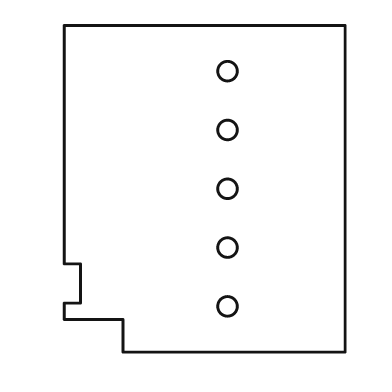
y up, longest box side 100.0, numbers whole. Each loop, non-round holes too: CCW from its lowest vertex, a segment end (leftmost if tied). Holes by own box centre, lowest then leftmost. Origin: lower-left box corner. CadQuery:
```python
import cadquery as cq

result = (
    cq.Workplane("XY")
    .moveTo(18.0, 0.0)
    .lineTo(86.0, 0.0)
    .lineTo(86.0, 100.0)
    .lineTo(0.0, 100.0)
    .lineTo(0.0, 27.0)
    .lineTo(5.0, 27.0)
    .lineTo(5.0, 15.0)
    .lineTo(0.0, 15.0)
    .lineTo(0.0, 10.0)
    .lineTo(18.0, 10.0)
    .close()
    .moveTo(50.0, 14.0)
    .circle(3.0)
    .moveTo(50.0, 32.0)
    .circle(3.0)
    .moveTo(50.0, 50.0)
    .circle(3.0)
    .moveTo(50.0, 68.0)
    .circle(3.0)
    .moveTo(50.0, 86.0)
    .circle(3.0)
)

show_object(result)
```